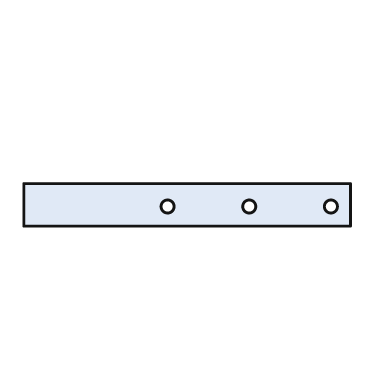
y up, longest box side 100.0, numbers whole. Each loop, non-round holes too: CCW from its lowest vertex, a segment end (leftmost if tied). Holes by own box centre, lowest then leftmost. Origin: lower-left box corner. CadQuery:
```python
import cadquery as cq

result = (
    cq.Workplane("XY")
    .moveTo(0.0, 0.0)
    .lineTo(100.0, 0.0)
    .lineTo(100.0, 13.0)
    .lineTo(0.0, 13.0)
    .close()
    .moveTo(44.0, 6.0)
    .circle(2.0)
    .moveTo(69.0, 6.0)
    .circle(2.0)
    .moveTo(94.0, 6.0)
    .circle(2.0)
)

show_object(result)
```